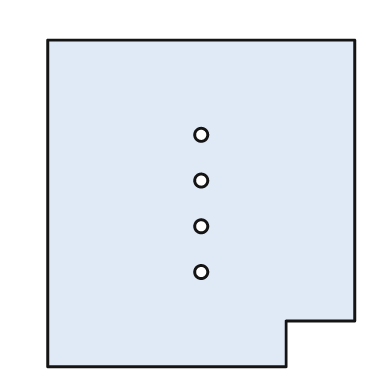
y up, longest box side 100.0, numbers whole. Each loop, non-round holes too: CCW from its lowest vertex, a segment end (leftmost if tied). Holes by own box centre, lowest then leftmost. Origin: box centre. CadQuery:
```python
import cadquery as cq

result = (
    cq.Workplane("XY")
    .moveTo(-47.0, -50.0)
    .lineTo(26.0, -50.0)
    .lineTo(26.0, -36.0)
    .lineTo(47.0, -36.0)
    .lineTo(47.0, 50.0)
    .lineTo(-47.0, 50.0)
    .close()
    .moveTo(0.0, -21.0)
    .circle(2.0)
    .moveTo(0.0, -7.0)
    .circle(2.0)
    .moveTo(0.0, 7.0)
    .circle(2.0)
    .moveTo(0.0, 21.0)
    .circle(2.0)
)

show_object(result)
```